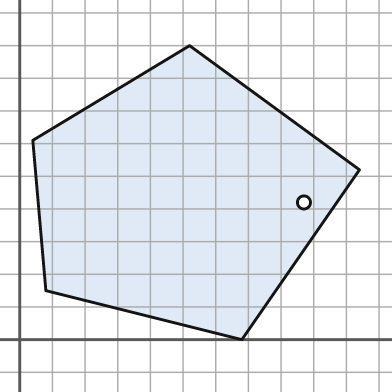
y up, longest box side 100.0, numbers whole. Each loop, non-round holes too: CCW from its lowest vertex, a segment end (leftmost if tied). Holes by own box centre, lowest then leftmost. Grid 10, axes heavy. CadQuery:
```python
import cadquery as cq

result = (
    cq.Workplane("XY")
    .moveTo(68.0, 0.0)
    .lineTo(104.0, 52.0)
    .lineTo(52.0, 90.0)
    .lineTo(4.0, 61.0)
    .lineTo(8.0, 15.0)
    .close()
    .moveTo(87.0, 42.0)
    .circle(2.0)
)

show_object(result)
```